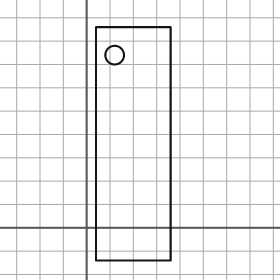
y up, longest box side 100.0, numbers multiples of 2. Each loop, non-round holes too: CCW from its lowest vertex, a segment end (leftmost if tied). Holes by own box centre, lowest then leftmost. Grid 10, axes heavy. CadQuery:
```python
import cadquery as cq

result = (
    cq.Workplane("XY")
    .moveTo(4.0, -14.0)
    .lineTo(36.0, -14.0)
    .lineTo(36.0, 86.0)
    .lineTo(4.0, 86.0)
    .close()
    .moveTo(12.0, 74.0)
    .circle(4.0)
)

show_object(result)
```